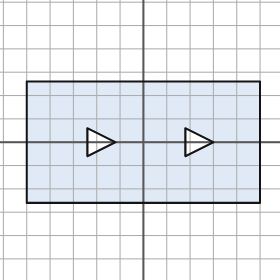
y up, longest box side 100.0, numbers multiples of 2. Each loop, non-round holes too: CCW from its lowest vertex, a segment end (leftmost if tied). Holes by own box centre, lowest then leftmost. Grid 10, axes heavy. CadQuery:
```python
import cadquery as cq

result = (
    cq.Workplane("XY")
    .moveTo(-50.0, -26.0)
    .lineTo(50.0, -26.0)
    .lineTo(50.0, 26.0)
    .lineTo(-50.0, 26.0)
    .close()
    .moveTo(-24.0, -6.0)
    .lineTo(-12.0, 0.0)
    .lineTo(-24.0, 6.0)
    .close()
    .moveTo(18.0, -6.0)
    .lineTo(30.0, 0.0)
    .lineTo(18.0, 6.0)
    .close()
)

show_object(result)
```